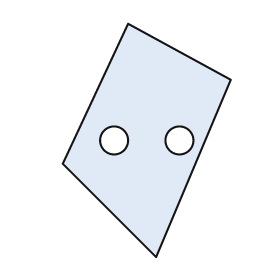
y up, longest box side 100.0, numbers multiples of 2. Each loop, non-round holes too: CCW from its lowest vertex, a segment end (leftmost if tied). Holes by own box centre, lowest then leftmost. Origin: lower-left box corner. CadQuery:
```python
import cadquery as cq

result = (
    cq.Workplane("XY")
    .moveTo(40.0, 0.0)
    .lineTo(72.0, 76.0)
    .lineTo(28.0, 100.0)
    .lineTo(0.0, 40.0)
    .close()
    .moveTo(22.0, 50.0)
    .circle(6.0)
    .moveTo(50.0, 50.0)
    .circle(6.0)
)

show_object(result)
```